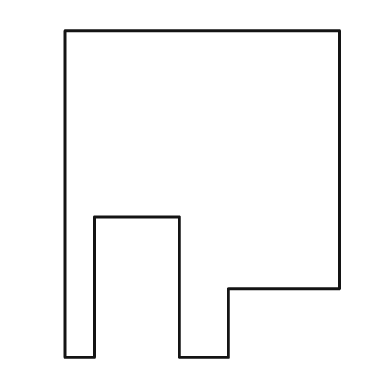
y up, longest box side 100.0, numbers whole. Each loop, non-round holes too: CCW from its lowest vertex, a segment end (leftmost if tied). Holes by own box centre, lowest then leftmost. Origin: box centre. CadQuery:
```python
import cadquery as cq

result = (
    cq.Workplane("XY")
    .moveTo(-42.0, -50.0)
    .lineTo(-33.0, -50.0)
    .lineTo(-33.0, -7.0)
    .lineTo(-7.0, -7.0)
    .lineTo(-7.0, -50.0)
    .lineTo(8.0, -50.0)
    .lineTo(8.0, -29.0)
    .lineTo(42.0, -29.0)
    .lineTo(42.0, 50.0)
    .lineTo(-42.0, 50.0)
    .close()
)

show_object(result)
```